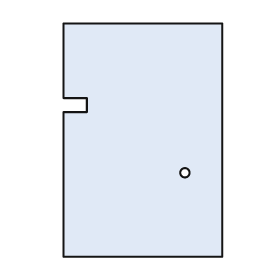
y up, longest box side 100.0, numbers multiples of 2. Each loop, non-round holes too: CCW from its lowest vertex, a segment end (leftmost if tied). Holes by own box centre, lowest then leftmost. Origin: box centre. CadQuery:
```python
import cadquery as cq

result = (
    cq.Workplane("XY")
    .moveTo(-34.0, -50.0)
    .lineTo(34.0, -50.0)
    .lineTo(34.0, 50.0)
    .lineTo(-34.0, 50.0)
    .lineTo(-34.0, 18.0)
    .lineTo(-24.0, 18.0)
    .lineTo(-24.0, 12.0)
    .lineTo(-34.0, 12.0)
    .close()
    .moveTo(18.0, -14.0)
    .circle(2.0)
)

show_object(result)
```